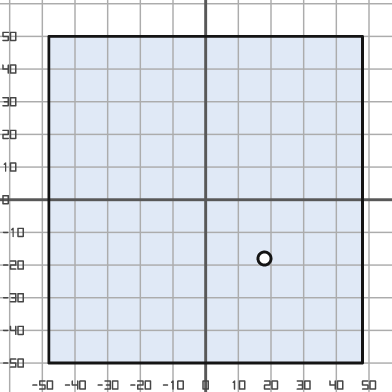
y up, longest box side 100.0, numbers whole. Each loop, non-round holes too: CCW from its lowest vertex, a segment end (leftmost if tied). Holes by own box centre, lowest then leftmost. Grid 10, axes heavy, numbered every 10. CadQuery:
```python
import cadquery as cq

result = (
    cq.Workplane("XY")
    .moveTo(-48.0, -50.0)
    .lineTo(48.0, -50.0)
    .lineTo(48.0, 50.0)
    .lineTo(-48.0, 50.0)
    .close()
    .moveTo(18.0, -18.0)
    .circle(2.0)
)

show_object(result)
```